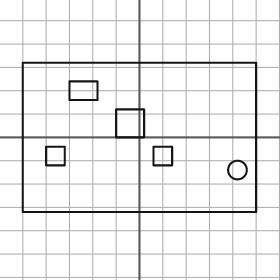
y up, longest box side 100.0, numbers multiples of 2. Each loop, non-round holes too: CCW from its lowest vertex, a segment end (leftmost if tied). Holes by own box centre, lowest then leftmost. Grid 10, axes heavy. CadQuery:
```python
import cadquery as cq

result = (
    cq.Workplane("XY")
    .moveTo(-50.0, -32.0)
    .lineTo(50.0, -32.0)
    .lineTo(50.0, 32.0)
    .lineTo(-50.0, 32.0)
    .close()
    .moveTo(42.0, -14.0)
    .circle(4.0)
    .moveTo(-40.0, -12.0)
    .lineTo(-32.0, -12.0)
    .lineTo(-32.0, -4.0)
    .lineTo(-40.0, -4.0)
    .close()
    .moveTo(6.0, -12.0)
    .lineTo(14.0, -12.0)
    .lineTo(14.0, -4.0)
    .lineTo(6.0, -4.0)
    .close()
    .moveTo(-10.0, 0.0)
    .lineTo(2.0, 0.0)
    .lineTo(2.0, 12.0)
    .lineTo(-10.0, 12.0)
    .close()
    .moveTo(-30.0, 16.0)
    .lineTo(-18.0, 16.0)
    .lineTo(-18.0, 24.0)
    .lineTo(-30.0, 24.0)
    .close()
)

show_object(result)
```